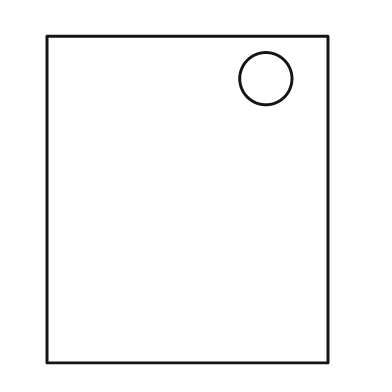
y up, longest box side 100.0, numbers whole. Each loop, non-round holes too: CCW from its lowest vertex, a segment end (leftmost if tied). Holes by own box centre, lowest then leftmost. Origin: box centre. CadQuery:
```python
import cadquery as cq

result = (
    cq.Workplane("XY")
    .moveTo(-43.0, -50.0)
    .lineTo(43.0, -50.0)
    .lineTo(43.0, 50.0)
    .lineTo(-43.0, 50.0)
    .close()
    .moveTo(24.0, 37.0)
    .circle(8.0)
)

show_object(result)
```